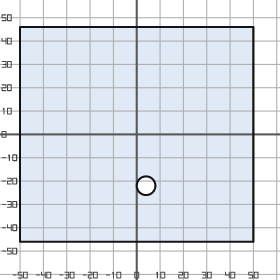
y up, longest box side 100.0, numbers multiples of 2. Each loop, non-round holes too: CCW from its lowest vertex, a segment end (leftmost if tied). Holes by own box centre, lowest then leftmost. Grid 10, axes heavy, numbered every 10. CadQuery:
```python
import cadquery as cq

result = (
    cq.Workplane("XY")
    .moveTo(-50.0, -46.0)
    .lineTo(50.0, -46.0)
    .lineTo(50.0, 46.0)
    .lineTo(-50.0, 46.0)
    .close()
    .moveTo(4.0, -22.0)
    .circle(4.0)
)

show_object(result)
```